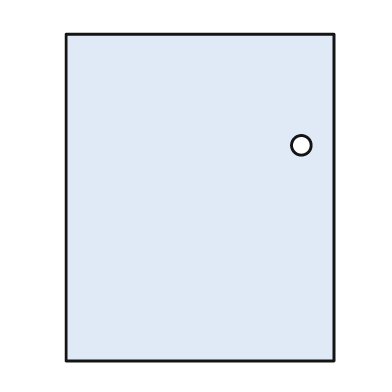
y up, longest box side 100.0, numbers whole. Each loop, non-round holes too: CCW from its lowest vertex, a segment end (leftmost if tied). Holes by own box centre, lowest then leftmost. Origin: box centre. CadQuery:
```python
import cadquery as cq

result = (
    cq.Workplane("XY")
    .moveTo(-41.0, -50.0)
    .lineTo(41.0, -50.0)
    .lineTo(41.0, 50.0)
    .lineTo(-41.0, 50.0)
    .close()
    .moveTo(31.0, 16.0)
    .circle(3.0)
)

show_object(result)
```